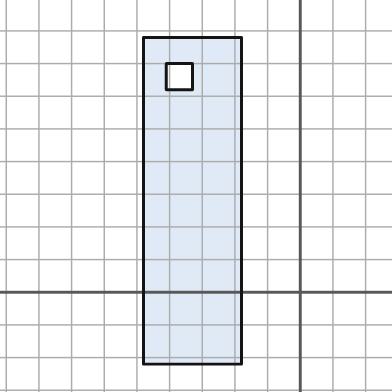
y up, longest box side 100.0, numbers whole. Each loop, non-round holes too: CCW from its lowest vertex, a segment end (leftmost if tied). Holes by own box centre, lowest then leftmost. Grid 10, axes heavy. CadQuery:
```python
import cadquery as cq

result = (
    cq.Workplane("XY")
    .moveTo(-48.0, -22.0)
    .lineTo(-18.0, -22.0)
    .lineTo(-18.0, 78.0)
    .lineTo(-48.0, 78.0)
    .close()
    .moveTo(-41.0, 62.0)
    .lineTo(-33.0, 62.0)
    .lineTo(-33.0, 70.0)
    .lineTo(-41.0, 70.0)
    .close()
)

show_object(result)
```